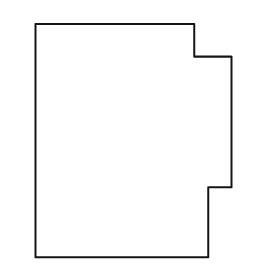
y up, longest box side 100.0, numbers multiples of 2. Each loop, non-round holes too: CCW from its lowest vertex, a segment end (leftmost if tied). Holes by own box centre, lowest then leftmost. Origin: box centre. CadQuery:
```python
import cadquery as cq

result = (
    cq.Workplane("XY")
    .moveTo(-42.0, -50.0)
    .lineTo(32.0, -50.0)
    .lineTo(32.0, -20.0)
    .lineTo(42.0, -20.0)
    .lineTo(42.0, 36.0)
    .lineTo(26.0, 36.0)
    .lineTo(26.0, 50.0)
    .lineTo(-42.0, 50.0)
    .close()
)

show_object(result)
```